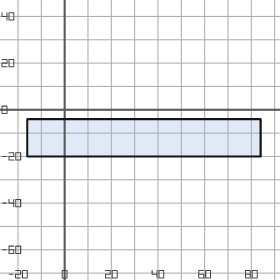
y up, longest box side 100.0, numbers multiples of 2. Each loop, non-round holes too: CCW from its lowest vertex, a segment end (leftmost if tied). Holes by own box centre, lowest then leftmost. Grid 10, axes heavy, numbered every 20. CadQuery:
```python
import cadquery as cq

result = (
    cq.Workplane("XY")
    .moveTo(-16.0, -20.0)
    .lineTo(84.0, -20.0)
    .lineTo(84.0, -4.0)
    .lineTo(-16.0, -4.0)
    .close()
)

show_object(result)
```